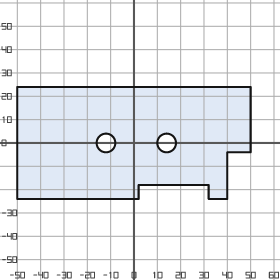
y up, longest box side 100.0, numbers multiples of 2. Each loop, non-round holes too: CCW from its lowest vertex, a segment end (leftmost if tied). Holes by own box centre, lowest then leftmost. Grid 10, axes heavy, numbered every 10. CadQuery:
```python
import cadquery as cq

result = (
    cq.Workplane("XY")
    .moveTo(-50.0, -24.0)
    .lineTo(2.0, -24.0)
    .lineTo(2.0, -18.0)
    .lineTo(32.0, -18.0)
    .lineTo(32.0, -24.0)
    .lineTo(40.0, -24.0)
    .lineTo(40.0, -4.0)
    .lineTo(50.0, -4.0)
    .lineTo(50.0, 24.0)
    .lineTo(-50.0, 24.0)
    .close()
    .moveTo(-12.0, 0.0)
    .circle(4.0)
    .moveTo(14.0, 0.0)
    .circle(4.0)
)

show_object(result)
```